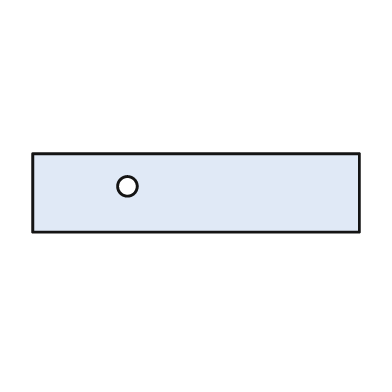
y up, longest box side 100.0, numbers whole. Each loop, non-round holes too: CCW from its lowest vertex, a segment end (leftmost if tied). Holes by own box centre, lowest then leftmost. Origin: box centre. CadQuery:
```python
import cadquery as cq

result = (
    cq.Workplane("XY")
    .moveTo(-50.0, -12.0)
    .lineTo(50.0, -12.0)
    .lineTo(50.0, 12.0)
    .lineTo(-50.0, 12.0)
    .close()
    .moveTo(-21.0, 2.0)
    .circle(3.0)
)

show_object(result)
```